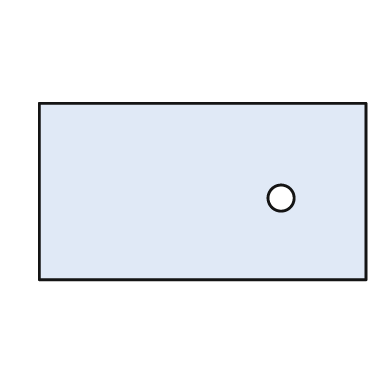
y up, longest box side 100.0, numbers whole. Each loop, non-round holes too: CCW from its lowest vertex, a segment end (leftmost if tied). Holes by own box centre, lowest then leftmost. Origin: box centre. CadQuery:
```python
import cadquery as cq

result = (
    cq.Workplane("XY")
    .moveTo(-50.0, -27.0)
    .lineTo(50.0, -27.0)
    .lineTo(50.0, 27.0)
    .lineTo(-50.0, 27.0)
    .close()
    .moveTo(24.0, -2.0)
    .circle(4.0)
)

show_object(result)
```